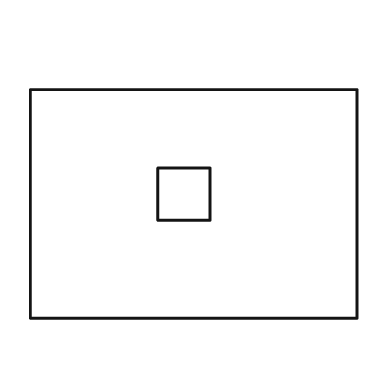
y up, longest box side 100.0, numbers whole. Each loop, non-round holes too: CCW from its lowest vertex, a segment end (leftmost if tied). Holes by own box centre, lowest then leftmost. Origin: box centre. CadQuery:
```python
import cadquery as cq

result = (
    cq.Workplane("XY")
    .moveTo(-50.0, -35.0)
    .lineTo(50.0, -35.0)
    .lineTo(50.0, 35.0)
    .lineTo(-50.0, 35.0)
    .close()
    .moveTo(-11.0, -5.0)
    .lineTo(5.0, -5.0)
    .lineTo(5.0, 11.0)
    .lineTo(-11.0, 11.0)
    .close()
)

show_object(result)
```